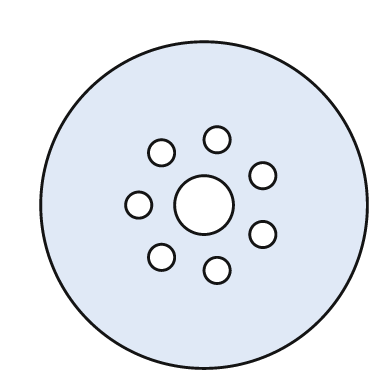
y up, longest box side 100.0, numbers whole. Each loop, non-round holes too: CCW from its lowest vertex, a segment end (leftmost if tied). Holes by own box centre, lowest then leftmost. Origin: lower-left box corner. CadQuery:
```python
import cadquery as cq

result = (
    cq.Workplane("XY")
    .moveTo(50.0, 50.0)
    .circle(50.0)
    .moveTo(54.0, 30.0)
    .circle(4.0)
    .moveTo(37.0, 34.0)
    .circle(4.0)
    .moveTo(68.0, 41.0)
    .circle(4.0)
    .moveTo(30.0, 50.0)
    .circle(4.0)
    .moveTo(50.0, 50.0)
    .circle(9.0)
    .moveTo(68.0, 59.0)
    .circle(4.0)
    .moveTo(37.0, 66.0)
    .circle(4.0)
    .moveTo(54.0, 70.0)
    .circle(4.0)
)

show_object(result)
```